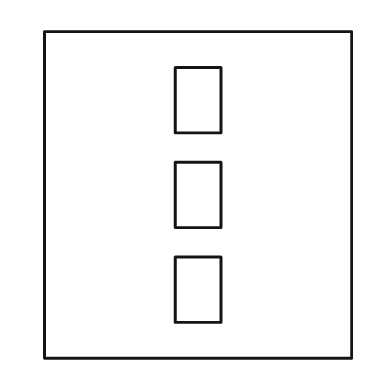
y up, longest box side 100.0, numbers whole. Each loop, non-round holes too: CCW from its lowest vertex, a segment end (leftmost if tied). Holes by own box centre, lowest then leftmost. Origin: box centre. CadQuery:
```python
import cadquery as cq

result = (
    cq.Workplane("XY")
    .moveTo(-47.0, -50.0)
    .lineTo(47.0, -50.0)
    .lineTo(47.0, 50.0)
    .lineTo(-47.0, 50.0)
    .close()
    .moveTo(-7.0, -39.0)
    .lineTo(7.0, -39.0)
    .lineTo(7.0, -19.0)
    .lineTo(-7.0, -19.0)
    .close()
    .moveTo(-7.0, -10.0)
    .lineTo(7.0, -10.0)
    .lineTo(7.0, 10.0)
    .lineTo(-7.0, 10.0)
    .close()
    .moveTo(-7.0, 19.0)
    .lineTo(7.0, 19.0)
    .lineTo(7.0, 39.0)
    .lineTo(-7.0, 39.0)
    .close()
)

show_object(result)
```